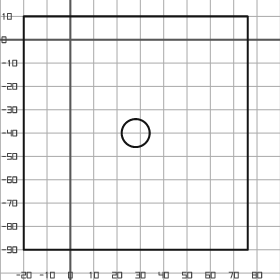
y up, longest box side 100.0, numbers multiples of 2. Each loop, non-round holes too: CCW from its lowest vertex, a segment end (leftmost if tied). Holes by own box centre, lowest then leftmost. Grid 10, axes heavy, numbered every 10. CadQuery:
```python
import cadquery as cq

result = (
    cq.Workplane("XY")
    .moveTo(-20.0, -90.0)
    .lineTo(76.0, -90.0)
    .lineTo(76.0, 10.0)
    .lineTo(-20.0, 10.0)
    .close()
    .moveTo(28.0, -40.0)
    .circle(6.0)
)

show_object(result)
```